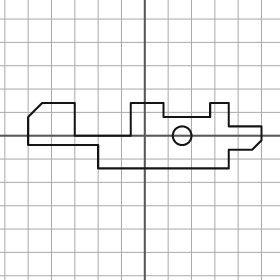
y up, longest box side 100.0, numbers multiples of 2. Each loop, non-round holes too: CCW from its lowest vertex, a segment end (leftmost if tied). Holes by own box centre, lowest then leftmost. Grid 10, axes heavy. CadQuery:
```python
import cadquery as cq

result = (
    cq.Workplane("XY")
    .moveTo(-20.0, -14.0)
    .lineTo(36.0, -14.0)
    .lineTo(36.0, -6.0)
    .lineTo(46.0, -6.0)
    .lineTo(50.0, -2.0)
    .lineTo(50.0, 4.0)
    .lineTo(36.0, 4.0)
    .lineTo(36.0, 14.0)
    .lineTo(28.0, 14.0)
    .lineTo(28.0, 8.0)
    .lineTo(8.0, 8.0)
    .lineTo(8.0, 14.0)
    .lineTo(-6.0, 14.0)
    .lineTo(-6.0, 0.0)
    .lineTo(-30.0, 0.0)
    .lineTo(-30.0, 14.0)
    .lineTo(-44.0, 14.0)
    .lineTo(-50.0, 8.0)
    .lineTo(-50.0, -4.0)
    .lineTo(-20.0, -4.0)
    .close()
    .moveTo(16.0, 0.0)
    .circle(4.0)
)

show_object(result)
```